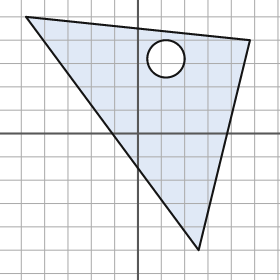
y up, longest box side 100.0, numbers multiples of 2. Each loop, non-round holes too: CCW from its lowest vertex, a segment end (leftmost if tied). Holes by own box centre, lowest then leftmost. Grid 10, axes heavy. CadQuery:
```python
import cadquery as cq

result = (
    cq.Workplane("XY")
    .moveTo(26.0, -50.0)
    .lineTo(48.0, 40.0)
    .lineTo(-48.0, 50.0)
    .close()
    .moveTo(12.0, 32.0)
    .circle(8.0)
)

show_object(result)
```